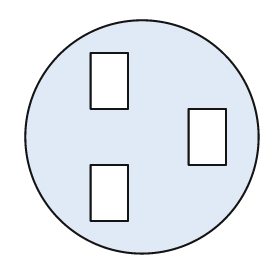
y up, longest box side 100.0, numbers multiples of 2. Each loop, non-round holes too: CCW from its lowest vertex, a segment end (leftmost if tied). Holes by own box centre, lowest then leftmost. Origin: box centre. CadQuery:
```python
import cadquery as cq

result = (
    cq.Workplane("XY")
    .moveTo(0.0, 0.0)
    .circle(50.0)
    .moveTo(-22.0, -36.0)
    .lineTo(-6.0, -36.0)
    .lineTo(-6.0, -12.0)
    .lineTo(-22.0, -12.0)
    .close()
    .moveTo(20.0, -12.0)
    .lineTo(36.0, -12.0)
    .lineTo(36.0, 12.0)
    .lineTo(20.0, 12.0)
    .close()
    .moveTo(-22.0, 12.0)
    .lineTo(-6.0, 12.0)
    .lineTo(-6.0, 36.0)
    .lineTo(-22.0, 36.0)
    .close()
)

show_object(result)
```